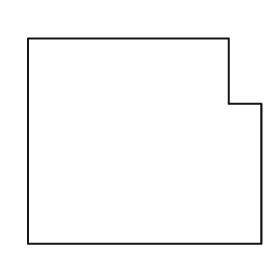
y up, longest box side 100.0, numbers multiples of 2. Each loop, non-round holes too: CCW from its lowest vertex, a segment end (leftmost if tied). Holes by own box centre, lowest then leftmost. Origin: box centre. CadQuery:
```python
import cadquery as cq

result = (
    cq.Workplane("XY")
    .moveTo(-50.0, -44.0)
    .lineTo(50.0, -44.0)
    .lineTo(50.0, 16.0)
    .lineTo(36.0, 16.0)
    .lineTo(36.0, 44.0)
    .lineTo(-50.0, 44.0)
    .close()
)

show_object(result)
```